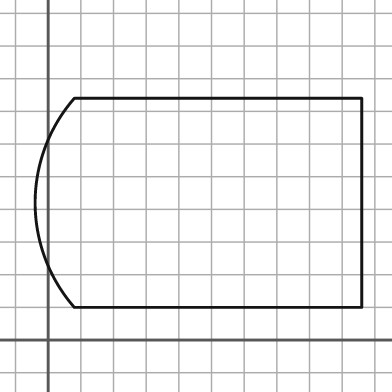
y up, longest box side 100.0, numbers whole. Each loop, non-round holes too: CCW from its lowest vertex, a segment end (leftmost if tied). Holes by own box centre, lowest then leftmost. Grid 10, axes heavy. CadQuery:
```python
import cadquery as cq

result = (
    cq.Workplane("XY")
    .moveTo(8.0, 10.0)
    .lineTo(96.0, 10.0)
    .lineTo(96.0, 74.0)
    .lineTo(8.0, 74.0)
    .threePointArc((-4.0, 42.0), (8.0, 10.0))
    .close()
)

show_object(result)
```